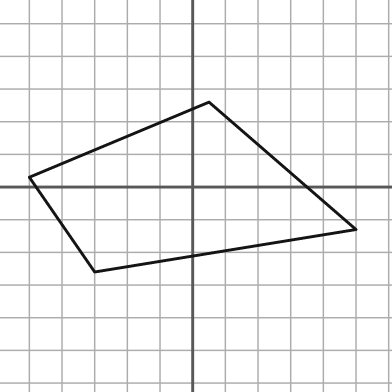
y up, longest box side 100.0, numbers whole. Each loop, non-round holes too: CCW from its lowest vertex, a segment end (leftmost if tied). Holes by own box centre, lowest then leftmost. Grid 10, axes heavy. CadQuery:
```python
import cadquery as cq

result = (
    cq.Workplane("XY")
    .moveTo(-30.0, -26.0)
    .lineTo(50.0, -13.0)
    .lineTo(5.0, 26.0)
    .lineTo(-50.0, 3.0)
    .close()
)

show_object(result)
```